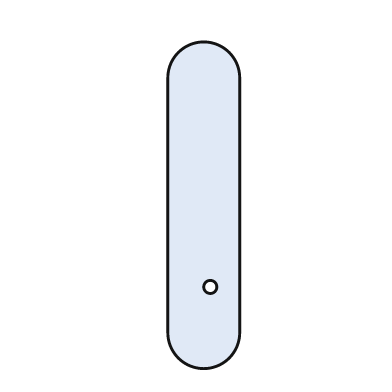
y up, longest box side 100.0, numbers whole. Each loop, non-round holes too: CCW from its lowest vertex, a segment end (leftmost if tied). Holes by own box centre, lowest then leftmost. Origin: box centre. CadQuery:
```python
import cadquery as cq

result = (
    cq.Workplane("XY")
    .moveTo(-11.0, -39.0)
    .threePointArc((0.0, -50.0), (11.0, -39.0))
    .lineTo(11.0, 39.0)
    .threePointArc((0.0, 50.0), (-11.0, 39.0))
    .close()
    .moveTo(2.0, -25.0)
    .circle(2.0)
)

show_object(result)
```